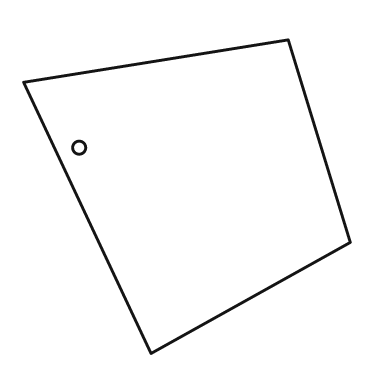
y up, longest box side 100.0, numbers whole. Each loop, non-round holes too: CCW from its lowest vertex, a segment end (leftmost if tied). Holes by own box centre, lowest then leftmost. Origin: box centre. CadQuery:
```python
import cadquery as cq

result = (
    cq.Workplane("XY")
    .moveTo(-11.0, -48.0)
    .lineTo(50.0, -14.0)
    .lineTo(31.0, 48.0)
    .lineTo(-50.0, 35.0)
    .close()
    .moveTo(-33.0, 15.0)
    .circle(2.0)
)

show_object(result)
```